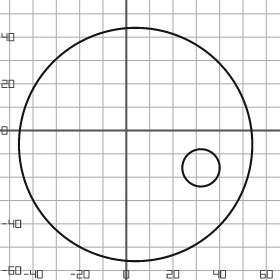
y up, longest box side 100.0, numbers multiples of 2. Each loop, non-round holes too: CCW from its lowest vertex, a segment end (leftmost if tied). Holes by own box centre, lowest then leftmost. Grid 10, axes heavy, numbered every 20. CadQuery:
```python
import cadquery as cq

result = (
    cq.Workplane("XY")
    .moveTo(4.0, -6.0)
    .circle(50.0)
    .moveTo(32.0, -16.0)
    .circle(8.0)
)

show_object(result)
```